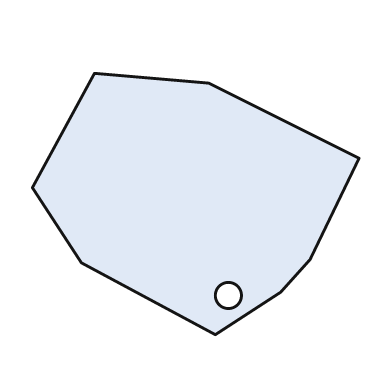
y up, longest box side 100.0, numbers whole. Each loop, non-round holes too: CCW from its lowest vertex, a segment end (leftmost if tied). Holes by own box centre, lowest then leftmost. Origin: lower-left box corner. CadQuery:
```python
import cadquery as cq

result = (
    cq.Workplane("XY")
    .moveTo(56.0, 0.0)
    .lineTo(76.0, 13.0)
    .lineTo(85.0, 23.0)
    .lineTo(100.0, 54.0)
    .lineTo(54.0, 77.0)
    .lineTo(19.0, 80.0)
    .lineTo(0.0, 45.0)
    .lineTo(15.0, 22.0)
    .close()
    .moveTo(60.0, 12.0)
    .circle(4.0)
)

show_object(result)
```